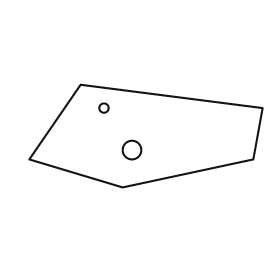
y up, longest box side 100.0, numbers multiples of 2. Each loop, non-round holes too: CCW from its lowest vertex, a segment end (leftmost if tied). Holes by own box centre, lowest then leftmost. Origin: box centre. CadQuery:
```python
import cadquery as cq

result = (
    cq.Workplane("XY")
    .moveTo(-10.0, -22.0)
    .lineTo(46.0, -10.0)
    .lineTo(50.0, 12.0)
    .lineTo(-28.0, 22.0)
    .lineTo(-50.0, -10.0)
    .close()
    .moveTo(-6.0, -6.0)
    .circle(4.0)
    .moveTo(-18.0, 12.0)
    .circle(2.0)
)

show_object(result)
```